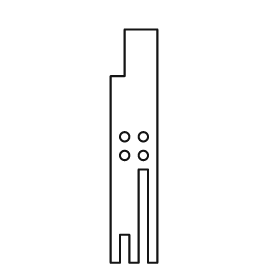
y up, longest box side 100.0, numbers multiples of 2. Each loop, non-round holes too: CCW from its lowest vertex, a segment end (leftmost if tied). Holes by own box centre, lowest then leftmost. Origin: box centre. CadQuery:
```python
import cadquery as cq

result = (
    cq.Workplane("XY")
    .moveTo(-10.0, -50.0)
    .lineTo(-6.0, -50.0)
    .lineTo(-6.0, -38.0)
    .lineTo(-2.0, -38.0)
    .lineTo(-2.0, -50.0)
    .lineTo(2.0, -50.0)
    .lineTo(2.0, -10.0)
    .lineTo(6.0, -10.0)
    .lineTo(6.0, -50.0)
    .lineTo(10.0, -50.0)
    .lineTo(10.0, 50.0)
    .lineTo(-4.0, 50.0)
    .lineTo(-4.0, 30.0)
    .lineTo(-10.0, 30.0)
    .close()
    .moveTo(-4.0, -4.0)
    .circle(2.0)
    .moveTo(4.0, -4.0)
    .circle(2.0)
    .moveTo(-4.0, 4.0)
    .circle(2.0)
    .moveTo(4.0, 4.0)
    .circle(2.0)
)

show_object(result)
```